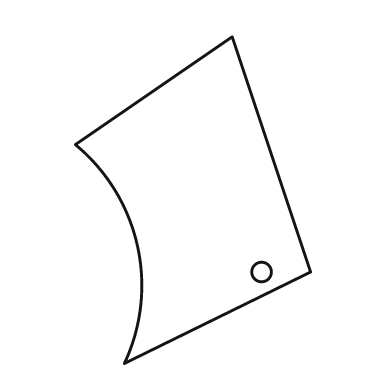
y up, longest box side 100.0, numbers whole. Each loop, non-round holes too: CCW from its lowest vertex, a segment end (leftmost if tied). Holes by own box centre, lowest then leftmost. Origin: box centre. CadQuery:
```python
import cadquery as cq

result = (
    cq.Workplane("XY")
    .moveTo(-21.0, -50.0)
    .lineTo(36.0, -22.0)
    .lineTo(12.0, 50.0)
    .lineTo(-36.0, 17.0)
    .threePointArc((-17.0, -14.0), (-21.0, -50.0))
    .close()
    .moveTo(21.0, -22.0)
    .circle(3.0)
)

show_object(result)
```